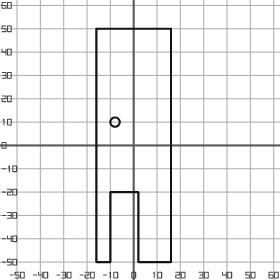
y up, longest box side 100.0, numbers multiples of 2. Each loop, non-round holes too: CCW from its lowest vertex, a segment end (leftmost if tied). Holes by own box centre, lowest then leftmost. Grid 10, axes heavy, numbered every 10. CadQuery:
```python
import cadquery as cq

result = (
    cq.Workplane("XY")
    .moveTo(-16.0, -50.0)
    .lineTo(-10.0, -50.0)
    .lineTo(-10.0, -20.0)
    .lineTo(2.0, -20.0)
    .lineTo(2.0, -50.0)
    .lineTo(16.0, -50.0)
    .lineTo(16.0, 50.0)
    .lineTo(-16.0, 50.0)
    .close()
    .moveTo(-8.0, 10.0)
    .circle(2.0)
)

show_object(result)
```